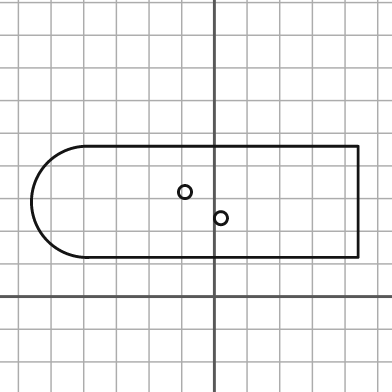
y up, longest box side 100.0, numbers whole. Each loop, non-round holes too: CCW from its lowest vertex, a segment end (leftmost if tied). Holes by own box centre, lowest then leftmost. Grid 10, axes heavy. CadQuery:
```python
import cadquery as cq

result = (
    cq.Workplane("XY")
    .moveTo(-38.0, 12.0)
    .lineTo(44.0, 12.0)
    .lineTo(44.0, 46.0)
    .lineTo(-38.0, 46.0)
    .threePointArc((-56.0, 29.0), (-38.0, 12.0))
    .close()
    .moveTo(2.0, 24.0)
    .circle(2.0)
    .moveTo(-9.0, 32.0)
    .circle(2.0)
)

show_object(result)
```